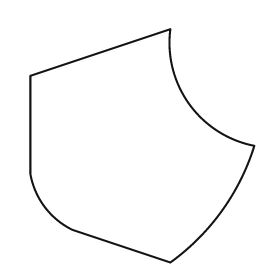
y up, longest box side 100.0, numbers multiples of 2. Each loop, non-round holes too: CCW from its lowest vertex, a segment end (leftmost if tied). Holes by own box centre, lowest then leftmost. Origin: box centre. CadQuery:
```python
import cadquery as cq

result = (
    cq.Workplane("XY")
    .moveTo(12.0, -50.0)
    .threePointArc((34.0, -28.0), (48.0, 0.0))
    .threePointArc((20.0, 18.0), (12.0, 50.0))
    .lineTo(-48.0, 30.0)
    .lineTo(-48.0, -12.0)
    .threePointArc((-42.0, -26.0), (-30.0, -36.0))
    .close()
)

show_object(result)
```